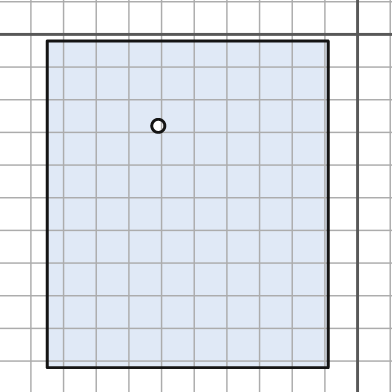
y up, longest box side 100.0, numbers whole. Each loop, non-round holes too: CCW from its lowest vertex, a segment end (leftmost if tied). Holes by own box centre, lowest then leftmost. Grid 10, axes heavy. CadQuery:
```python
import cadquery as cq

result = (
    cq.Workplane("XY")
    .moveTo(-95.0, -102.0)
    .lineTo(-9.0, -102.0)
    .lineTo(-9.0, -2.0)
    .lineTo(-95.0, -2.0)
    .close()
    .moveTo(-61.0, -28.0)
    .circle(2.0)
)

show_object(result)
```